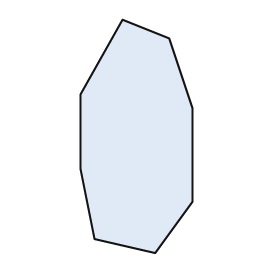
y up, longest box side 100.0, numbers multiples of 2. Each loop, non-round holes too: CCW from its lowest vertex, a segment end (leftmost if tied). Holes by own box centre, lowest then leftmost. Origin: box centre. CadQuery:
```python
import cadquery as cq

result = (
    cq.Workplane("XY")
    .moveTo(8.0, -50.0)
    .lineTo(24.0, -28.0)
    .lineTo(24.0, 12.0)
    .lineTo(14.0, 42.0)
    .lineTo(-6.0, 50.0)
    .lineTo(-24.0, 18.0)
    .lineTo(-24.0, -14.0)
    .lineTo(-18.0, -44.0)
    .close()
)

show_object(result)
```